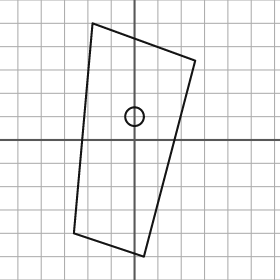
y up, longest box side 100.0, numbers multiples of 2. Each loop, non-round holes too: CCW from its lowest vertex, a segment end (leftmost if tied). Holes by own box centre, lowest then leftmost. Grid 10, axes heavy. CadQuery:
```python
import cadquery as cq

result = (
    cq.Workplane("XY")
    .moveTo(4.0, -50.0)
    .lineTo(26.0, 34.0)
    .lineTo(-18.0, 50.0)
    .lineTo(-26.0, -40.0)
    .close()
    .moveTo(0.0, 10.0)
    .circle(4.0)
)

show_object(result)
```